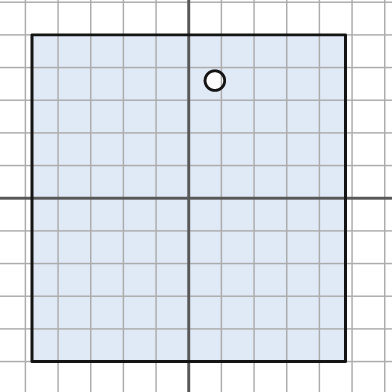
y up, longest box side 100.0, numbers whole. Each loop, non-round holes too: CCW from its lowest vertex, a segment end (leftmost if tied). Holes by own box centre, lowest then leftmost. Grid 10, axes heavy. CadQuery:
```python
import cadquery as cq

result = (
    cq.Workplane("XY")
    .moveTo(-48.0, -50.0)
    .lineTo(48.0, -50.0)
    .lineTo(48.0, 50.0)
    .lineTo(-48.0, 50.0)
    .close()
    .moveTo(8.0, 36.0)
    .circle(3.0)
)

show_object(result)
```